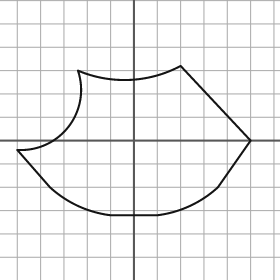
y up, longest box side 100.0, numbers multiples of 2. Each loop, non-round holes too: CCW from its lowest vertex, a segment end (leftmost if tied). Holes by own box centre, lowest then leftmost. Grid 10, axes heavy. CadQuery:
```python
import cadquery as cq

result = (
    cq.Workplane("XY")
    .moveTo(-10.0, -32.0)
    .lineTo(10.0, -32.0)
    .threePointArc((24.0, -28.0), (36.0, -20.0))
    .lineTo(50.0, 0.0)
    .lineTo(20.0, 32.0)
    .threePointArc((-2.0, 26.0), (-24.0, 30.0))
    .threePointArc((-28.0, 6.0), (-50.0, -4.0))
    .lineTo(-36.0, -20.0)
    .threePointArc((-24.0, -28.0), (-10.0, -32.0))
    .close()
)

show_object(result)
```